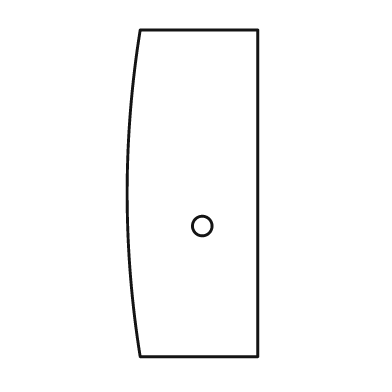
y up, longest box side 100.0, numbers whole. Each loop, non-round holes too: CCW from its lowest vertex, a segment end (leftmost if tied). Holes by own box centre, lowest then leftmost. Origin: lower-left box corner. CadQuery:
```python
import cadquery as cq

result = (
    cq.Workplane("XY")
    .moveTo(4.0, 0.0)
    .lineTo(40.0, 0.0)
    .lineTo(40.0, 100.0)
    .lineTo(4.0, 100.0)
    .threePointArc((0.0, 50.0), (4.0, 0.0))
    .close()
    .moveTo(23.0, 40.0)
    .circle(3.0)
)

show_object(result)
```